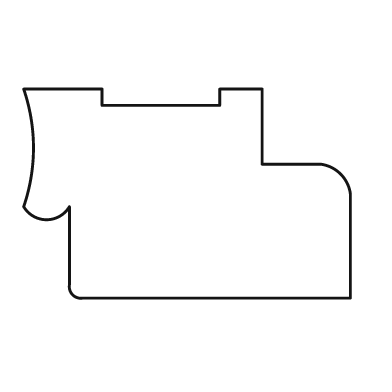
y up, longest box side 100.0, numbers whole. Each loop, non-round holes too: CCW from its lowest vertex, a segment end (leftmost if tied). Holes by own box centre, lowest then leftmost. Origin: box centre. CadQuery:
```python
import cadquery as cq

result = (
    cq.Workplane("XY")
    .moveTo(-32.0, -32.0)
    .lineTo(50.0, -32.0)
    .lineTo(50.0, 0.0)
    .threePointArc((47.0, 6.0), (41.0, 9.0))
    .lineTo(23.0, 9.0)
    .lineTo(23.0, 32.0)
    .lineTo(10.0, 32.0)
    .lineTo(10.0, 27.0)
    .lineTo(-26.0, 27.0)
    .lineTo(-26.0, 32.0)
    .lineTo(-50.0, 32.0)
    .threePointArc((-47.0, 14.0), (-50.0, -4.0))
    .threePointArc((-43.0, -8.0), (-36.0, -4.0))
    .lineTo(-36.0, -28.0)
    .threePointArc((-35.0, -31.0), (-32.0, -32.0))
    .close()
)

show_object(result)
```